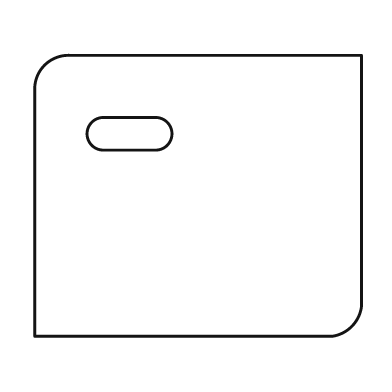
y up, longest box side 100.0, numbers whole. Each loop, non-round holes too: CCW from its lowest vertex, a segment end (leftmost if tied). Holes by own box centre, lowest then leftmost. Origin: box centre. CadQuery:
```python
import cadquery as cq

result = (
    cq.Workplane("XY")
    .moveTo(-50.0, -43.0)
    .lineTo(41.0, -43.0)
    .threePointArc((47.0, -40.0), (50.0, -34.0))
    .lineTo(50.0, 43.0)
    .lineTo(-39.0, 43.0)
    .threePointArc((-47.0, 40.0), (-50.0, 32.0))
    .close()
    .moveTo(-29.0, 14.0)
    .lineTo(-13.0, 14.0)
    .threePointArc((-8.0, 19.0), (-13.0, 24.0))
    .lineTo(-29.0, 24.0)
    .threePointArc((-34.0, 19.0), (-29.0, 14.0))
    .close()
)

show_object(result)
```